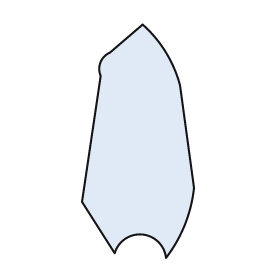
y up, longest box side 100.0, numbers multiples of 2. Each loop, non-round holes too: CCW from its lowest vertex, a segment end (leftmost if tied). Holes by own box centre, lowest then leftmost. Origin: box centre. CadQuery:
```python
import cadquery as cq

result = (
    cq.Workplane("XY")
    .moveTo(12.0, -50.0)
    .threePointArc((20.0, -36.0), (24.0, -20.0))
    .lineTo(18.0, 24.0)
    .threePointArc((12.0, 38.0), (2.0, 50.0))
    .lineTo(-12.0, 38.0)
    .threePointArc((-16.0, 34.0), (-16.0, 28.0))
    .lineTo(-24.0, -26.0)
    .lineTo(-10.0, -48.0)
    .threePointArc((2.0, -40.0), (12.0, -50.0))
    .close()
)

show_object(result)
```